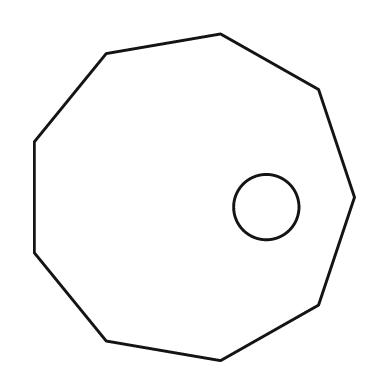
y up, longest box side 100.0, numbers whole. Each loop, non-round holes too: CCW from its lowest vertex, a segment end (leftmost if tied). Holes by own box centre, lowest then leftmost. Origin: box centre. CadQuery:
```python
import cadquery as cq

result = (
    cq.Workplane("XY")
    .moveTo(8.0, -50.0)
    .lineTo(38.0, -33.0)
    .lineTo(49.0, 0.0)
    .lineTo(38.0, 33.0)
    .lineTo(8.0, 50.0)
    .lineTo(-27.0, 44.0)
    .lineTo(-49.0, 17.0)
    .lineTo(-49.0, -17.0)
    .lineTo(-27.0, -44.0)
    .close()
    .moveTo(22.0, -3.0)
    .circle(10.0)
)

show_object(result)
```